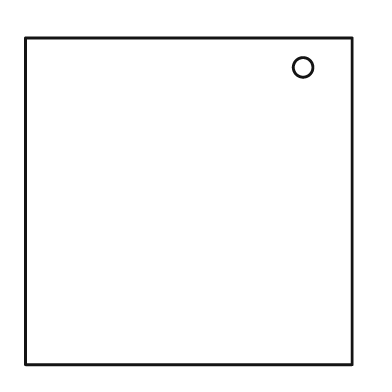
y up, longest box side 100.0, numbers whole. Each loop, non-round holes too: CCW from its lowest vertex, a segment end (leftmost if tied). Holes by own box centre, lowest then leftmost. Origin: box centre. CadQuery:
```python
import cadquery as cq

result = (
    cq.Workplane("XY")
    .moveTo(-50.0, -50.0)
    .lineTo(50.0, -50.0)
    .lineTo(50.0, 50.0)
    .lineTo(-50.0, 50.0)
    .close()
    .moveTo(35.0, 41.0)
    .circle(3.0)
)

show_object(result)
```